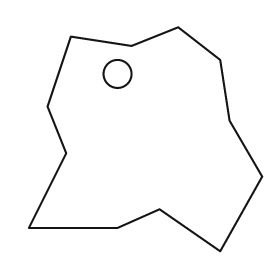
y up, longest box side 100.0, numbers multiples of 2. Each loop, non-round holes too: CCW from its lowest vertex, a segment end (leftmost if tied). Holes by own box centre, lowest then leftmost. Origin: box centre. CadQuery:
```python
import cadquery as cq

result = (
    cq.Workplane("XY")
    .moveTo(32.0, -48.0)
    .lineTo(50.0, -16.0)
    .lineTo(36.0, 8.0)
    .lineTo(32.0, 34.0)
    .lineTo(14.0, 48.0)
    .lineTo(-6.0, 40.0)
    .lineTo(-32.0, 44.0)
    .lineTo(-42.0, 14.0)
    .lineTo(-34.0, -6.0)
    .lineTo(-50.0, -38.0)
    .lineTo(-12.0, -38.0)
    .lineTo(6.0, -30.0)
    .close()
    .moveTo(-12.0, 28.0)
    .circle(6.0)
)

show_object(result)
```